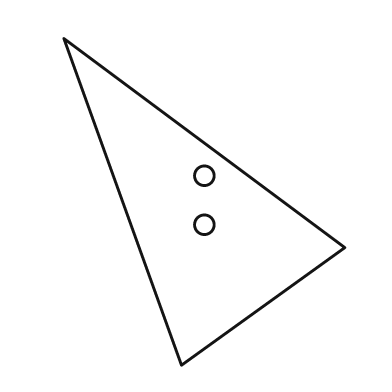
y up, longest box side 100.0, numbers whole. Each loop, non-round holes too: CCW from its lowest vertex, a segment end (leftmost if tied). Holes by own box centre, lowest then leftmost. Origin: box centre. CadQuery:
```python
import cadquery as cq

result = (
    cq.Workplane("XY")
    .moveTo(-7.0, -50.0)
    .lineTo(43.0, -14.0)
    .lineTo(-43.0, 50.0)
    .close()
    .moveTo(0.0, -7.0)
    .circle(3.0)
    .moveTo(0.0, 8.0)
    .circle(3.0)
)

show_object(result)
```